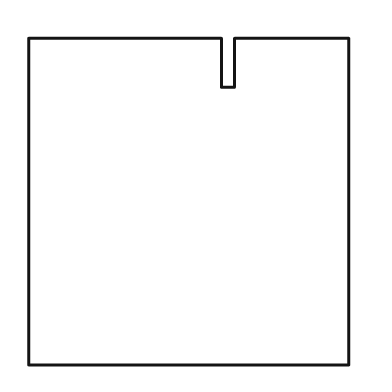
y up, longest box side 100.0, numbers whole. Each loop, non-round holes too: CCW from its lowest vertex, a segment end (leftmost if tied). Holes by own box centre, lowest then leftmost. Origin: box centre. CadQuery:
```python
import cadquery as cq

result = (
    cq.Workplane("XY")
    .moveTo(-49.0, -50.0)
    .lineTo(49.0, -50.0)
    .lineTo(49.0, 50.0)
    .lineTo(14.0, 50.0)
    .lineTo(14.0, 35.0)
    .lineTo(10.0, 35.0)
    .lineTo(10.0, 50.0)
    .lineTo(-49.0, 50.0)
    .close()
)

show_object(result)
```